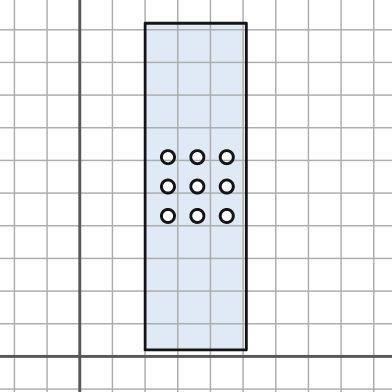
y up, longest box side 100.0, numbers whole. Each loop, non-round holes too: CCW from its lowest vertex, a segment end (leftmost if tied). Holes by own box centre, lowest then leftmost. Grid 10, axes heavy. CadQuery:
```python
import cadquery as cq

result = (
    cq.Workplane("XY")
    .moveTo(20.0, 2.0)
    .lineTo(51.0, 2.0)
    .lineTo(51.0, 102.0)
    .lineTo(20.0, 102.0)
    .close()
    .moveTo(27.0, 43.0)
    .circle(2.0)
    .moveTo(36.0, 43.0)
    .circle(2.0)
    .moveTo(45.0, 43.0)
    .circle(2.0)
    .moveTo(27.0, 52.0)
    .circle(2.0)
    .moveTo(36.0, 52.0)
    .circle(2.0)
    .moveTo(45.0, 52.0)
    .circle(2.0)
    .moveTo(27.0, 61.0)
    .circle(2.0)
    .moveTo(36.0, 61.0)
    .circle(2.0)
    .moveTo(45.0, 61.0)
    .circle(2.0)
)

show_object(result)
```